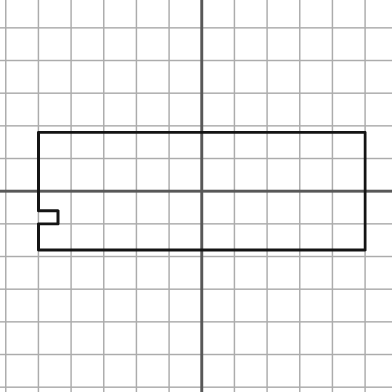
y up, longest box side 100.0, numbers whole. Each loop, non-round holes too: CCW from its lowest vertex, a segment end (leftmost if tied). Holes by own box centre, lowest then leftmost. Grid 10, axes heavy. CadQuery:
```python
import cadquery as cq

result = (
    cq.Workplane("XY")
    .moveTo(-50.0, -18.0)
    .lineTo(50.0, -18.0)
    .lineTo(50.0, 18.0)
    .lineTo(-50.0, 18.0)
    .lineTo(-50.0, -6.0)
    .lineTo(-44.0, -6.0)
    .lineTo(-44.0, -10.0)
    .lineTo(-50.0, -10.0)
    .close()
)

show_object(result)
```